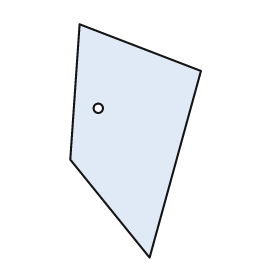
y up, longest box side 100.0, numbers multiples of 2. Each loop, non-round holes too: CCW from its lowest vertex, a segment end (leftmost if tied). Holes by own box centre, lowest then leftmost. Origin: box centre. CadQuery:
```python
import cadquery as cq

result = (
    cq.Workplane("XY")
    .moveTo(6.0, -50.0)
    .lineTo(28.0, 30.0)
    .lineTo(-24.0, 50.0)
    .lineTo(-28.0, -8.0)
    .close()
    .moveTo(-16.0, 14.0)
    .circle(2.0)
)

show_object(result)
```